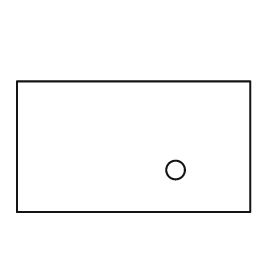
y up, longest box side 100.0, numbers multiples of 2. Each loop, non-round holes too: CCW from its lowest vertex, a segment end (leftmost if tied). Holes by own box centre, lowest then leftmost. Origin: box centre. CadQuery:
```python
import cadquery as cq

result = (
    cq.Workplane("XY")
    .moveTo(-50.0, -28.0)
    .lineTo(50.0, -28.0)
    .lineTo(50.0, 28.0)
    .lineTo(-50.0, 28.0)
    .close()
    .moveTo(18.0, -10.0)
    .circle(4.0)
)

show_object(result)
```